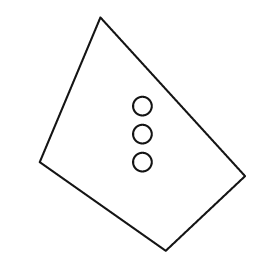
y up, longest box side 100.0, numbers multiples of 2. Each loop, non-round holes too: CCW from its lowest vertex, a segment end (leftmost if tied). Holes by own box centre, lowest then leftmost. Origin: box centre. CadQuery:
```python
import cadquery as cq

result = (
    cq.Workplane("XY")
    .moveTo(10.0, -50.0)
    .lineTo(44.0, -18.0)
    .lineTo(-18.0, 50.0)
    .lineTo(-44.0, -12.0)
    .close()
    .moveTo(0.0, -12.0)
    .circle(4.0)
    .moveTo(0.0, 0.0)
    .circle(4.0)
    .moveTo(0.0, 12.0)
    .circle(4.0)
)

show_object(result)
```